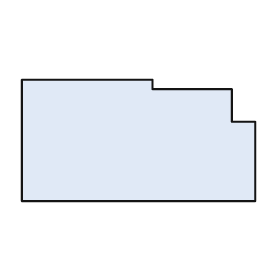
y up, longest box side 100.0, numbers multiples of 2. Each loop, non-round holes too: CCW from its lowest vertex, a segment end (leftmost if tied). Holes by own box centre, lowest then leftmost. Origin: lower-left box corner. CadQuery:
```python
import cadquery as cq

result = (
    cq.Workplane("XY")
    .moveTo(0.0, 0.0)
    .lineTo(100.0, 0.0)
    .lineTo(100.0, 34.0)
    .lineTo(90.0, 34.0)
    .lineTo(90.0, 48.0)
    .lineTo(56.0, 48.0)
    .lineTo(56.0, 52.0)
    .lineTo(0.0, 52.0)
    .close()
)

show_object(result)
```